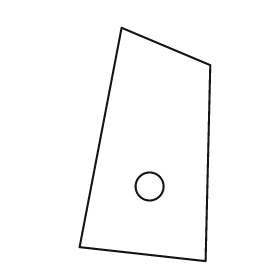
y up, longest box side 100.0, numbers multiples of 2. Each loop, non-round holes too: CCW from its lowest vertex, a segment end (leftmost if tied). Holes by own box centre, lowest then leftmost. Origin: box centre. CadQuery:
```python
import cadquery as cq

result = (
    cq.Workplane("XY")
    .moveTo(26.0, -50.0)
    .lineTo(28.0, 34.0)
    .lineTo(-10.0, 50.0)
    .lineTo(-28.0, -44.0)
    .close()
    .moveTo(2.0, -18.0)
    .circle(6.0)
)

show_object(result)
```